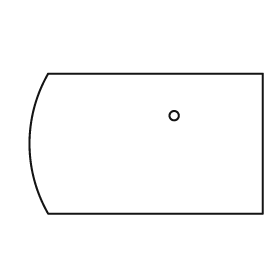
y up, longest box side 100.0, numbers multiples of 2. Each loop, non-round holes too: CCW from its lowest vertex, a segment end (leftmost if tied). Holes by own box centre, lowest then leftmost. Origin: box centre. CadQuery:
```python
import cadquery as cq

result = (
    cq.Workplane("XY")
    .moveTo(-42.0, -30.0)
    .lineTo(50.0, -30.0)
    .lineTo(50.0, 30.0)
    .lineTo(-42.0, 30.0)
    .threePointArc((-50.0, 0.0), (-42.0, -30.0))
    .close()
    .moveTo(12.0, 12.0)
    .circle(2.0)
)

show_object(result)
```